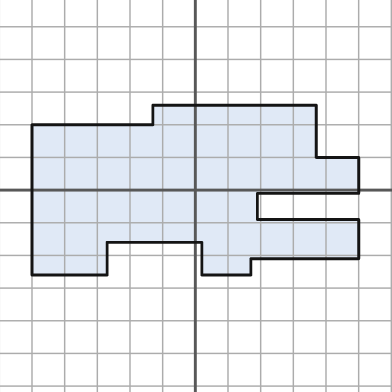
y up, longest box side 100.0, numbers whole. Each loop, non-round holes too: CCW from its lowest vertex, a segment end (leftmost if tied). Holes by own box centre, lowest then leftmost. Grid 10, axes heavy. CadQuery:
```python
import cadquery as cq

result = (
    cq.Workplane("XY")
    .moveTo(-50.0, -26.0)
    .lineTo(-27.0, -26.0)
    .lineTo(-27.0, -16.0)
    .lineTo(2.0, -16.0)
    .lineTo(2.0, -26.0)
    .lineTo(17.0, -26.0)
    .lineTo(17.0, -21.0)
    .lineTo(50.0, -21.0)
    .lineTo(50.0, -9.0)
    .lineTo(19.0, -9.0)
    .lineTo(19.0, -1.0)
    .lineTo(50.0, -1.0)
    .lineTo(50.0, 10.0)
    .lineTo(37.0, 10.0)
    .lineTo(37.0, 26.0)
    .lineTo(-13.0, 26.0)
    .lineTo(-13.0, 20.0)
    .lineTo(-50.0, 20.0)
    .close()
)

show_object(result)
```